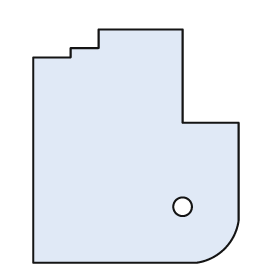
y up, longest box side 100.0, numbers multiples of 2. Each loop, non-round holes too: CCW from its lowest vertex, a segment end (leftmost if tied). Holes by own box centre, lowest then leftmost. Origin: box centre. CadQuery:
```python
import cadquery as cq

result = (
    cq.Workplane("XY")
    .moveTo(-44.0, -50.0)
    .lineTo(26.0, -50.0)
    .threePointArc((38.0, -44.0), (44.0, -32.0))
    .lineTo(44.0, 10.0)
    .lineTo(20.0, 10.0)
    .lineTo(20.0, 50.0)
    .lineTo(-16.0, 50.0)
    .lineTo(-16.0, 42.0)
    .lineTo(-28.0, 42.0)
    .lineTo(-28.0, 38.0)
    .lineTo(-44.0, 38.0)
    .close()
    .moveTo(20.0, -26.0)
    .circle(4.0)
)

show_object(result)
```